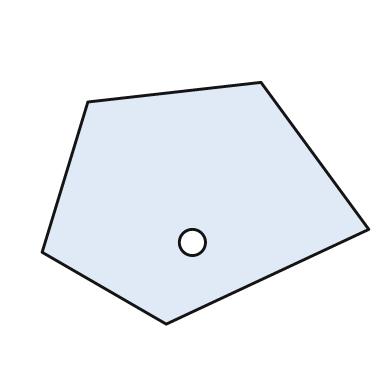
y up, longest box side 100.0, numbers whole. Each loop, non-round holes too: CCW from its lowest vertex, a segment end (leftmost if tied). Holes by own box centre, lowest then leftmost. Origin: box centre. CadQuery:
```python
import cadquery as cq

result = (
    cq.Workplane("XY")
    .moveTo(-12.0, -37.0)
    .lineTo(50.0, -8.0)
    .lineTo(17.0, 37.0)
    .lineTo(-36.0, 31.0)
    .lineTo(-50.0, -15.0)
    .close()
    .moveTo(-4.0, -12.0)
    .circle(4.0)
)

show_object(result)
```